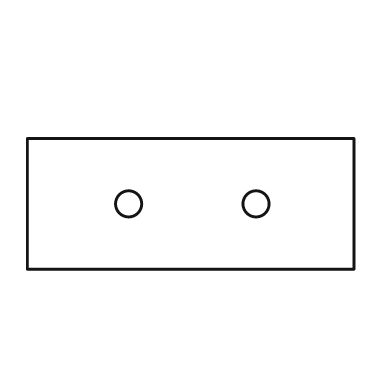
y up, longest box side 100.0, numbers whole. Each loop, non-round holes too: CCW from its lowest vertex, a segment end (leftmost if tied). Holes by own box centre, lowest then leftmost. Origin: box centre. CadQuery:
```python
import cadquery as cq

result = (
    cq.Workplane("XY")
    .moveTo(-50.0, -20.0)
    .lineTo(50.0, -20.0)
    .lineTo(50.0, 20.0)
    .lineTo(-50.0, 20.0)
    .close()
    .moveTo(-19.0, 0.0)
    .circle(4.0)
    .moveTo(20.0, 0.0)
    .circle(4.0)
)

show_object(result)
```